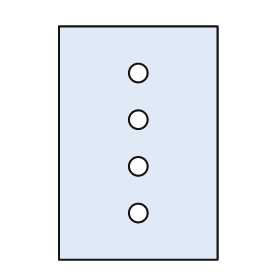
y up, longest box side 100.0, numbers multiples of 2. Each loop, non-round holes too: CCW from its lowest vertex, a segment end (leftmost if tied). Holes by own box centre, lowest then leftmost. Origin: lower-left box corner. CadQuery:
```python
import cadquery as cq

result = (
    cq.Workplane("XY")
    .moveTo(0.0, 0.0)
    .lineTo(68.0, 0.0)
    .lineTo(68.0, 100.0)
    .lineTo(0.0, 100.0)
    .close()
    .moveTo(34.0, 20.0)
    .circle(4.0)
    .moveTo(34.0, 40.0)
    .circle(4.0)
    .moveTo(34.0, 60.0)
    .circle(4.0)
    .moveTo(34.0, 80.0)
    .circle(4.0)
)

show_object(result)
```